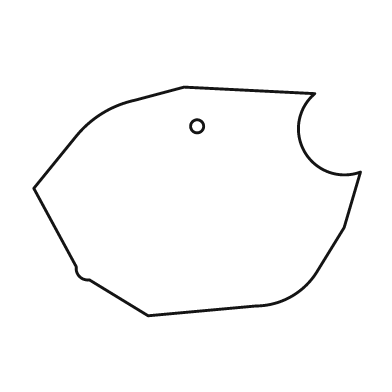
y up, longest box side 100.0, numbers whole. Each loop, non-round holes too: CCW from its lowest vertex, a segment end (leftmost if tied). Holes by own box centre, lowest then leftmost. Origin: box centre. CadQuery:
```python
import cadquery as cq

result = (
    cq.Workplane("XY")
    .moveTo(-15.0, -35.0)
    .lineTo(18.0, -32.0)
    .threePointArc((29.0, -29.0), (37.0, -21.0))
    .lineTo(45.0, -8.0)
    .lineTo(50.0, 9.0)
    .threePointArc((33.0, 15.0), (36.0, 33.0))
    .lineTo(-4.0, 35.0)
    .lineTo(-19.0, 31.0)
    .threePointArc((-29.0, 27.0), (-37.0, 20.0))
    .lineTo(-50.0, 4.0)
    .lineTo(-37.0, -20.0)
    .threePointArc((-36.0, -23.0), (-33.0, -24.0))
    .close()
    .moveTo(0.0, 23.0)
    .circle(2.0)
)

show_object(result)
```